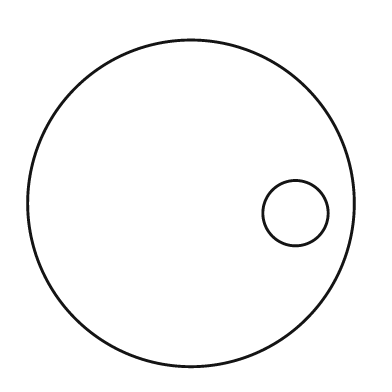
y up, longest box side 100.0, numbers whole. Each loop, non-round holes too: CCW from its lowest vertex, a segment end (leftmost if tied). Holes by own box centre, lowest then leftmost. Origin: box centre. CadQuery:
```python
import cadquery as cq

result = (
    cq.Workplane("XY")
    .moveTo(0.0, 0.0)
    .circle(50.0)
    .moveTo(32.0, -3.0)
    .circle(10.0)
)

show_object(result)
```